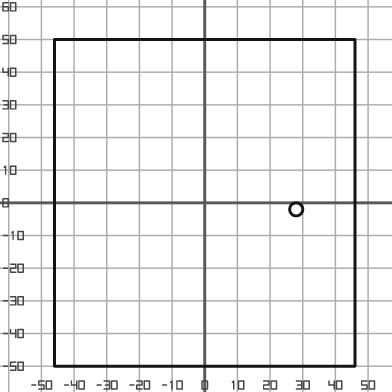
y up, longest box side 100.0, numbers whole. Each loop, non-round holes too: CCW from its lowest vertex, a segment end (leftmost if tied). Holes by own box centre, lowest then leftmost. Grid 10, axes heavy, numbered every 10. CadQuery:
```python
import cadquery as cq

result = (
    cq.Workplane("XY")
    .moveTo(-46.0, -50.0)
    .lineTo(46.0, -50.0)
    .lineTo(46.0, 50.0)
    .lineTo(-46.0, 50.0)
    .close()
    .moveTo(28.0, -2.0)
    .circle(2.0)
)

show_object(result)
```